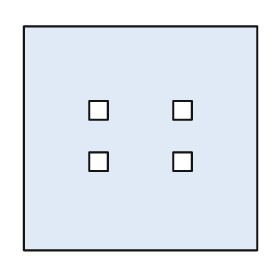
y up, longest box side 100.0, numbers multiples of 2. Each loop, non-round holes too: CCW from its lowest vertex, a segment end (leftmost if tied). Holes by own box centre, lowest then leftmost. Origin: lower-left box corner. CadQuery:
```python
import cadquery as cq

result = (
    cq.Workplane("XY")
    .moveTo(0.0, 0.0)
    .lineTo(100.0, 0.0)
    .lineTo(100.0, 96.0)
    .lineTo(0.0, 96.0)
    .close()
    .moveTo(28.0, 34.0)
    .lineTo(36.0, 34.0)
    .lineTo(36.0, 42.0)
    .lineTo(28.0, 42.0)
    .close()
    .moveTo(64.0, 34.0)
    .lineTo(72.0, 34.0)
    .lineTo(72.0, 42.0)
    .lineTo(64.0, 42.0)
    .close()
    .moveTo(28.0, 56.0)
    .lineTo(36.0, 56.0)
    .lineTo(36.0, 64.0)
    .lineTo(28.0, 64.0)
    .close()
    .moveTo(64.0, 56.0)
    .lineTo(72.0, 56.0)
    .lineTo(72.0, 64.0)
    .lineTo(64.0, 64.0)
    .close()
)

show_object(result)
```